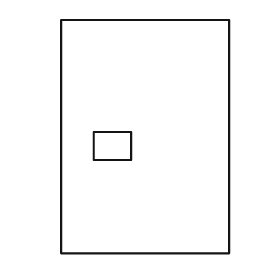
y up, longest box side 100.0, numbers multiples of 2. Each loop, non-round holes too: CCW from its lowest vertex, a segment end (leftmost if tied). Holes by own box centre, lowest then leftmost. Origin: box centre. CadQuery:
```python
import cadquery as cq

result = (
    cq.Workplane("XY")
    .moveTo(-36.0, -50.0)
    .lineTo(36.0, -50.0)
    .lineTo(36.0, 50.0)
    .lineTo(-36.0, 50.0)
    .close()
    .moveTo(-22.0, -10.0)
    .lineTo(-6.0, -10.0)
    .lineTo(-6.0, 2.0)
    .lineTo(-22.0, 2.0)
    .close()
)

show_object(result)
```